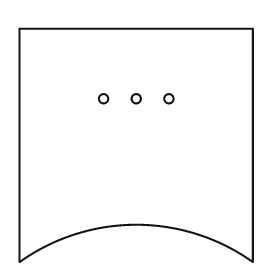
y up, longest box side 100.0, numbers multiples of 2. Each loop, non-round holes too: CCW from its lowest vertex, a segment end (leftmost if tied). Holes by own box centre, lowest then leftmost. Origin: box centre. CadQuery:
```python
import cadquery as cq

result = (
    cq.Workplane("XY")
    .moveTo(-50.0, -50.0)
    .threePointArc((0.0, -34.0), (50.0, -50.0))
    .lineTo(50.0, 50.0)
    .lineTo(-50.0, 50.0)
    .close()
    .moveTo(-14.0, 20.0)
    .circle(2.0)
    .moveTo(0.0, 20.0)
    .circle(2.0)
    .moveTo(14.0, 20.0)
    .circle(2.0)
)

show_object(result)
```